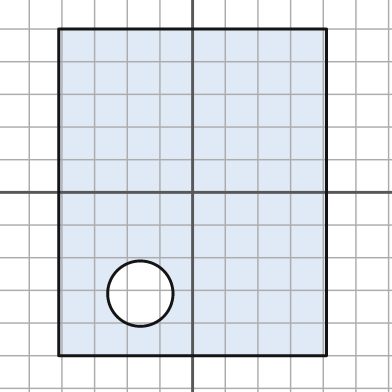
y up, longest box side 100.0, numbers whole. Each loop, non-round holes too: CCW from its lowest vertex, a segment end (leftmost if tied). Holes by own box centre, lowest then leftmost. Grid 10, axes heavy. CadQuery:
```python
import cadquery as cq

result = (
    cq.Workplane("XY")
    .moveTo(-41.0, -50.0)
    .lineTo(41.0, -50.0)
    .lineTo(41.0, 50.0)
    .lineTo(-41.0, 50.0)
    .close()
    .moveTo(-16.0, -31.0)
    .circle(10.0)
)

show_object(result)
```